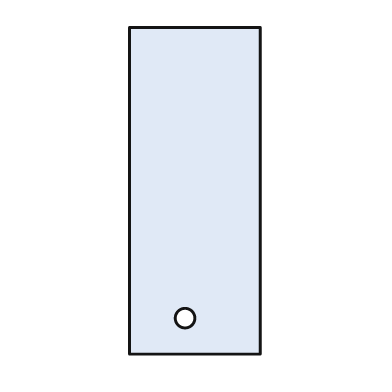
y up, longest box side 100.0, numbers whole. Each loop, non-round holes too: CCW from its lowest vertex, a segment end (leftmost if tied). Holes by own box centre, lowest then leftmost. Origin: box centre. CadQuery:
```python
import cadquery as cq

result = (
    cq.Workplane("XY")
    .moveTo(-20.0, -50.0)
    .lineTo(20.0, -50.0)
    .lineTo(20.0, 50.0)
    .lineTo(-20.0, 50.0)
    .close()
    .moveTo(-3.0, -39.0)
    .circle(3.0)
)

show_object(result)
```